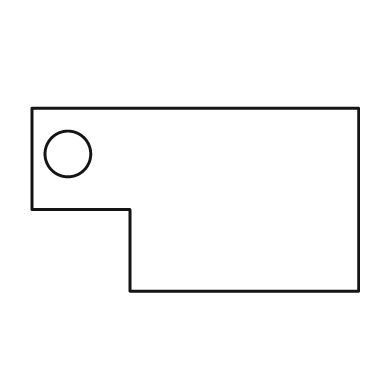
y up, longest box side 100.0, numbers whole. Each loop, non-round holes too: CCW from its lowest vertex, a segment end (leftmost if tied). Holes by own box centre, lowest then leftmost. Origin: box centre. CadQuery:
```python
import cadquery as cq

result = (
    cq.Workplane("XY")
    .moveTo(-20.0, -28.0)
    .lineTo(50.0, -28.0)
    .lineTo(50.0, 28.0)
    .lineTo(-50.0, 28.0)
    .lineTo(-50.0, -3.0)
    .lineTo(-20.0, -3.0)
    .close()
    .moveTo(-39.0, 14.0)
    .circle(7.0)
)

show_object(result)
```